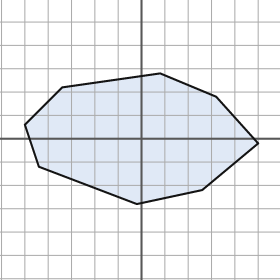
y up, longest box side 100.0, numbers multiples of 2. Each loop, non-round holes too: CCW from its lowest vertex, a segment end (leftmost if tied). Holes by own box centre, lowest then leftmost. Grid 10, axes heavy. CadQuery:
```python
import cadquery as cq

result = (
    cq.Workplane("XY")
    .moveTo(-2.0, -28.0)
    .lineTo(26.0, -22.0)
    .lineTo(50.0, -2.0)
    .lineTo(32.0, 18.0)
    .lineTo(8.0, 28.0)
    .lineTo(-34.0, 22.0)
    .lineTo(-50.0, 6.0)
    .lineTo(-44.0, -12.0)
    .close()
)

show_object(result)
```